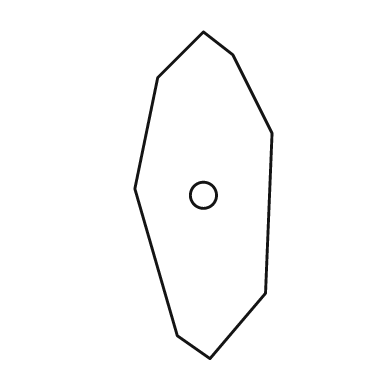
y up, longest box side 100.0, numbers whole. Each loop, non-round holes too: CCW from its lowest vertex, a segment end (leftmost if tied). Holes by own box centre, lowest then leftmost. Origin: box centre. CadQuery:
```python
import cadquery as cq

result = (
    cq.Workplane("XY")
    .moveTo(2.0, -50.0)
    .lineTo(19.0, -30.0)
    .lineTo(21.0, 19.0)
    .lineTo(9.0, 43.0)
    .lineTo(0.0, 50.0)
    .lineTo(-14.0, 36.0)
    .lineTo(-21.0, 2.0)
    .lineTo(-8.0, -43.0)
    .close()
    .moveTo(0.0, 0.0)
    .circle(4.0)
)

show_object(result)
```